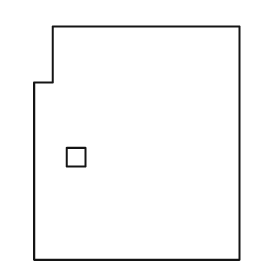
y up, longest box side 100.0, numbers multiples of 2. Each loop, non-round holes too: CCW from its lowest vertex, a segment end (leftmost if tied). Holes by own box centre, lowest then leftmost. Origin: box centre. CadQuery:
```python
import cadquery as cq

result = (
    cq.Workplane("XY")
    .moveTo(-44.0, -50.0)
    .lineTo(44.0, -50.0)
    .lineTo(44.0, 50.0)
    .lineTo(-36.0, 50.0)
    .lineTo(-36.0, 26.0)
    .lineTo(-44.0, 26.0)
    .close()
    .moveTo(-30.0, -10.0)
    .lineTo(-22.0, -10.0)
    .lineTo(-22.0, -2.0)
    .lineTo(-30.0, -2.0)
    .close()
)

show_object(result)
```